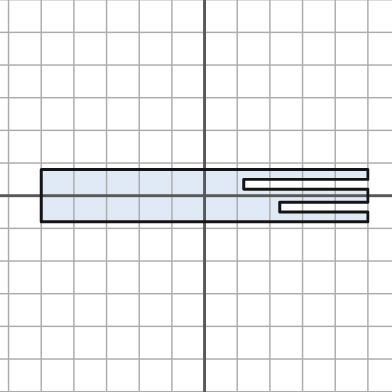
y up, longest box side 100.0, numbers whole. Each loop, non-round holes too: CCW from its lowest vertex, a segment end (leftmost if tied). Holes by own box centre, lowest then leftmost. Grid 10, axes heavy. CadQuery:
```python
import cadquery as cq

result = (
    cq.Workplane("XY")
    .moveTo(-50.0, -8.0)
    .lineTo(50.0, -8.0)
    .lineTo(50.0, -5.0)
    .lineTo(23.0, -5.0)
    .lineTo(23.0, -2.0)
    .lineTo(50.0, -2.0)
    .lineTo(50.0, 2.0)
    .lineTo(12.0, 2.0)
    .lineTo(12.0, 5.0)
    .lineTo(50.0, 5.0)
    .lineTo(50.0, 8.0)
    .lineTo(-50.0, 8.0)
    .close()
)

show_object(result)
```